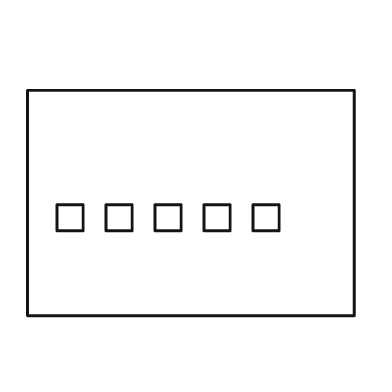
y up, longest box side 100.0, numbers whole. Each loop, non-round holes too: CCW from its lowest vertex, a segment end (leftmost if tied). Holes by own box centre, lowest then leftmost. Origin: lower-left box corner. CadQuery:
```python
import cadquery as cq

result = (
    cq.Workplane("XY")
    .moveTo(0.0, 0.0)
    .lineTo(100.0, 0.0)
    .lineTo(100.0, 69.0)
    .lineTo(0.0, 69.0)
    .close()
    .moveTo(9.0, 26.0)
    .lineTo(17.0, 26.0)
    .lineTo(17.0, 34.0)
    .lineTo(9.0, 34.0)
    .close()
    .moveTo(24.0, 26.0)
    .lineTo(32.0, 26.0)
    .lineTo(32.0, 34.0)
    .lineTo(24.0, 34.0)
    .close()
    .moveTo(39.0, 26.0)
    .lineTo(47.0, 26.0)
    .lineTo(47.0, 34.0)
    .lineTo(39.0, 34.0)
    .close()
    .moveTo(54.0, 26.0)
    .lineTo(62.0, 26.0)
    .lineTo(62.0, 34.0)
    .lineTo(54.0, 34.0)
    .close()
    .moveTo(69.0, 26.0)
    .lineTo(77.0, 26.0)
    .lineTo(77.0, 34.0)
    .lineTo(69.0, 34.0)
    .close()
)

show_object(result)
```